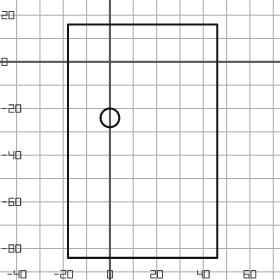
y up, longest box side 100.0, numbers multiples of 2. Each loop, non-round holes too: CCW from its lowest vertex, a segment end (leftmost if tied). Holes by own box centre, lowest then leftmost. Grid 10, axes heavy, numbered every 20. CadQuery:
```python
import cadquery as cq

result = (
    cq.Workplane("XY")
    .moveTo(-18.0, -84.0)
    .lineTo(46.0, -84.0)
    .lineTo(46.0, 16.0)
    .lineTo(-18.0, 16.0)
    .close()
    .moveTo(0.0, -24.0)
    .circle(4.0)
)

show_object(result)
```